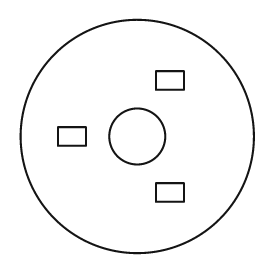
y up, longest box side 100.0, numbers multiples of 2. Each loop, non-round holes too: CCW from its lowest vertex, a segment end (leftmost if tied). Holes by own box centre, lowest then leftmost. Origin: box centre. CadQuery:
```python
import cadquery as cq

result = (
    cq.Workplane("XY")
    .moveTo(0.0, 0.0)
    .circle(50.0)
    .moveTo(8.0, -28.0)
    .lineTo(20.0, -28.0)
    .lineTo(20.0, -20.0)
    .lineTo(8.0, -20.0)
    .close()
    .moveTo(-34.0, -4.0)
    .lineTo(-22.0, -4.0)
    .lineTo(-22.0, 4.0)
    .lineTo(-34.0, 4.0)
    .close()
    .moveTo(0.0, 0.0)
    .circle(12.0)
    .moveTo(8.0, 20.0)
    .lineTo(20.0, 20.0)
    .lineTo(20.0, 28.0)
    .lineTo(8.0, 28.0)
    .close()
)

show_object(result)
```